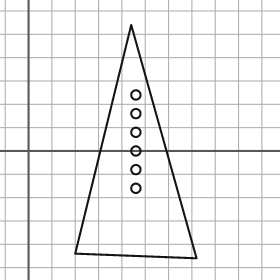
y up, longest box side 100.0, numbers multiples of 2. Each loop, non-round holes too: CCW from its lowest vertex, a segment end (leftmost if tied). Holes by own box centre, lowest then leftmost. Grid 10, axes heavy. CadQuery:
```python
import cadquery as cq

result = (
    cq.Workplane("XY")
    .moveTo(72.0, -46.0)
    .lineTo(44.0, 54.0)
    .lineTo(20.0, -44.0)
    .close()
    .moveTo(46.0, -16.0)
    .circle(2.0)
    .moveTo(46.0, -8.0)
    .circle(2.0)
    .moveTo(46.0, 0.0)
    .circle(2.0)
    .moveTo(46.0, 8.0)
    .circle(2.0)
    .moveTo(46.0, 16.0)
    .circle(2.0)
    .moveTo(46.0, 24.0)
    .circle(2.0)
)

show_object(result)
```